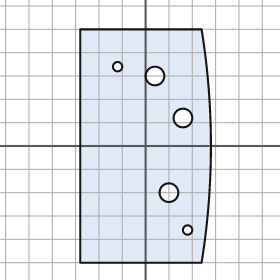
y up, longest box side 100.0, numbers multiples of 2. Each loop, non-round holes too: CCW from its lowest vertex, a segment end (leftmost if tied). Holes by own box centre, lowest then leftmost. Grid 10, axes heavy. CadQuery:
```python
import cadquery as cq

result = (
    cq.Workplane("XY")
    .moveTo(-28.0, -50.0)
    .lineTo(24.0, -50.0)
    .threePointArc((28.0, 0.0), (24.0, 50.0))
    .lineTo(-28.0, 50.0)
    .close()
    .moveTo(18.0, -36.0)
    .circle(2.0)
    .moveTo(10.0, -20.0)
    .circle(4.0)
    .moveTo(16.0, 12.0)
    .circle(4.0)
    .moveTo(4.0, 30.0)
    .circle(4.0)
    .moveTo(-12.0, 34.0)
    .circle(2.0)
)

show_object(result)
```